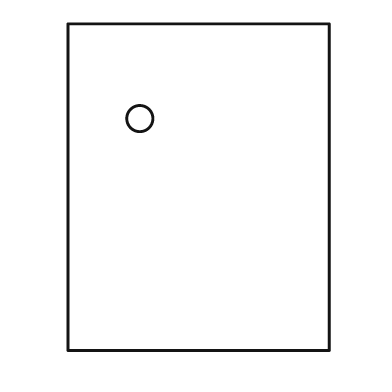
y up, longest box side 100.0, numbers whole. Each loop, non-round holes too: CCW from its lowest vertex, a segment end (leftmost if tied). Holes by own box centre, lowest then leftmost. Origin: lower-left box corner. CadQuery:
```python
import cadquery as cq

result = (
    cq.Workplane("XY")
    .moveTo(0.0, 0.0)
    .lineTo(80.0, 0.0)
    .lineTo(80.0, 100.0)
    .lineTo(0.0, 100.0)
    .close()
    .moveTo(22.0, 71.0)
    .circle(4.0)
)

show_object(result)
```